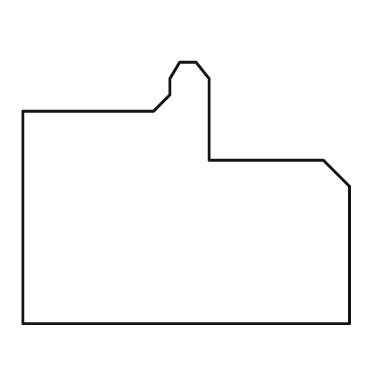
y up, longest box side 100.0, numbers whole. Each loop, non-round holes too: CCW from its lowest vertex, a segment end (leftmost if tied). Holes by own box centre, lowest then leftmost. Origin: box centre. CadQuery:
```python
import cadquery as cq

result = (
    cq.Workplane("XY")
    .moveTo(-50.0, -40.0)
    .lineTo(50.0, -40.0)
    .lineTo(50.0, 2.0)
    .lineTo(42.0, 10.0)
    .lineTo(7.0, 10.0)
    .lineTo(7.0, 35.0)
    .lineTo(3.0, 40.0)
    .lineTo(-2.0, 40.0)
    .lineTo(-5.0, 35.0)
    .lineTo(-5.0, 30.0)
    .lineTo(-10.0, 25.0)
    .lineTo(-50.0, 25.0)
    .close()
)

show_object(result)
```